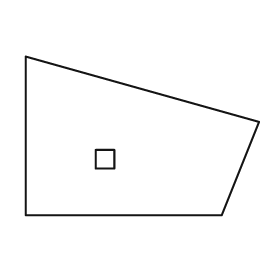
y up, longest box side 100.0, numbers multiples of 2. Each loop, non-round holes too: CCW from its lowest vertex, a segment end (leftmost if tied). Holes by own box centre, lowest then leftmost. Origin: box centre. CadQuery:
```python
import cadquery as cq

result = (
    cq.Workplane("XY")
    .moveTo(-50.0, -34.0)
    .lineTo(34.0, -34.0)
    .lineTo(50.0, 6.0)
    .lineTo(-50.0, 34.0)
    .close()
    .moveTo(-20.0, -14.0)
    .lineTo(-12.0, -14.0)
    .lineTo(-12.0, -6.0)
    .lineTo(-20.0, -6.0)
    .close()
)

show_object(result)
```